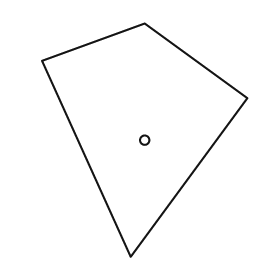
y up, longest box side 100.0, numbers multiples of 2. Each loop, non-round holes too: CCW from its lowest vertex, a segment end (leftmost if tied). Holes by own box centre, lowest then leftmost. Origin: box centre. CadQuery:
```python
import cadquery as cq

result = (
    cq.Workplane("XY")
    .moveTo(-6.0, -50.0)
    .lineTo(44.0, 18.0)
    .lineTo(0.0, 50.0)
    .lineTo(-44.0, 34.0)
    .close()
    .moveTo(0.0, 0.0)
    .circle(2.0)
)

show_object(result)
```